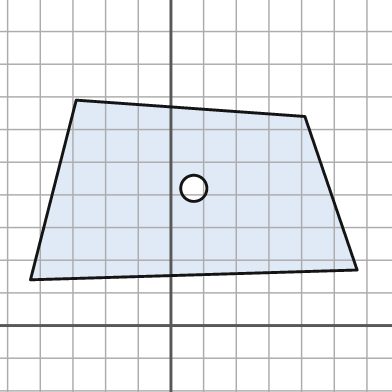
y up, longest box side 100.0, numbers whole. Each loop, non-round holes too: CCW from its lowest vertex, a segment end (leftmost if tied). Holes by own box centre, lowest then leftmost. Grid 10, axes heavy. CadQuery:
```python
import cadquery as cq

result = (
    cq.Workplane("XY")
    .moveTo(-43.0, 14.0)
    .lineTo(57.0, 17.0)
    .lineTo(41.0, 64.0)
    .lineTo(-29.0, 69.0)
    .close()
    .moveTo(7.0, 42.0)
    .circle(4.0)
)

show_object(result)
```